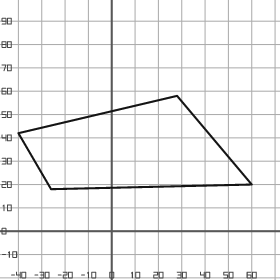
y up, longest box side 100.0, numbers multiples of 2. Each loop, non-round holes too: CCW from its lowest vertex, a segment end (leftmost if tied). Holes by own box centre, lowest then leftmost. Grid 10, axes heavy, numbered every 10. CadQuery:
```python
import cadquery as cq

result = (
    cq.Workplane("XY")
    .moveTo(-26.0, 18.0)
    .lineTo(60.0, 20.0)
    .lineTo(28.0, 58.0)
    .lineTo(-40.0, 42.0)
    .close()
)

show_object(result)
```